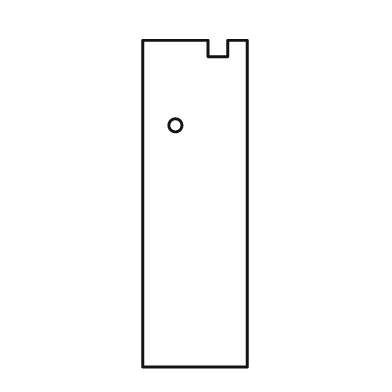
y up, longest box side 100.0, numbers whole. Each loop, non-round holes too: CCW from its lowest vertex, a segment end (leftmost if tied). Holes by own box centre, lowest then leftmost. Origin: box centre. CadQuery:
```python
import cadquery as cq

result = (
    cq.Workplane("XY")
    .moveTo(-16.0, -50.0)
    .lineTo(16.0, -50.0)
    .lineTo(16.0, 50.0)
    .lineTo(10.0, 50.0)
    .lineTo(10.0, 45.0)
    .lineTo(4.0, 45.0)
    .lineTo(4.0, 50.0)
    .lineTo(-16.0, 50.0)
    .close()
    .moveTo(-6.0, 24.0)
    .circle(2.0)
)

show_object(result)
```